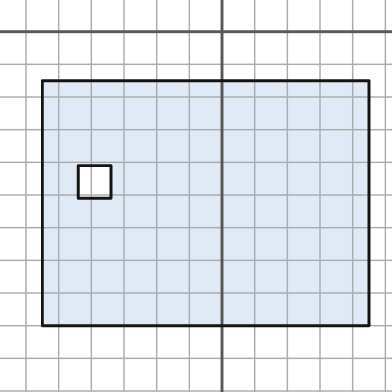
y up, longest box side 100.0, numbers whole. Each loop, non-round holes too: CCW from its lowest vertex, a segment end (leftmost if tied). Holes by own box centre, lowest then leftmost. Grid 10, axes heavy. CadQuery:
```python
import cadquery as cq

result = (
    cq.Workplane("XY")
    .moveTo(-55.0, -90.0)
    .lineTo(45.0, -90.0)
    .lineTo(45.0, -15.0)
    .lineTo(-55.0, -15.0)
    .close()
    .moveTo(-44.0, -51.0)
    .lineTo(-34.0, -51.0)
    .lineTo(-34.0, -41.0)
    .lineTo(-44.0, -41.0)
    .close()
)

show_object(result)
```